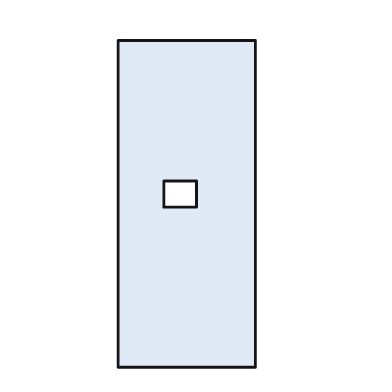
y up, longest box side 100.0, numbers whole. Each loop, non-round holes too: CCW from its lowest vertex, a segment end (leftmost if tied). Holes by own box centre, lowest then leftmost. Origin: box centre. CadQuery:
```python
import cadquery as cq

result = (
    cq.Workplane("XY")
    .moveTo(-21.0, -50.0)
    .lineTo(21.0, -50.0)
    .lineTo(21.0, 50.0)
    .lineTo(-21.0, 50.0)
    .close()
    .moveTo(-7.0, -1.0)
    .lineTo(3.0, -1.0)
    .lineTo(3.0, 7.0)
    .lineTo(-7.0, 7.0)
    .close()
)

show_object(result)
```